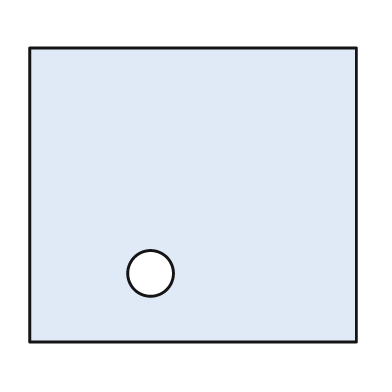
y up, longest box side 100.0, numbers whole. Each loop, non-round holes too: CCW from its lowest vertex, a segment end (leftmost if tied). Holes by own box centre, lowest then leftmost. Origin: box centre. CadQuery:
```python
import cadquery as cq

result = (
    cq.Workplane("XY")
    .moveTo(-50.0, -45.0)
    .lineTo(50.0, -45.0)
    .lineTo(50.0, 45.0)
    .lineTo(-50.0, 45.0)
    .close()
    .moveTo(-13.0, -24.0)
    .circle(7.0)
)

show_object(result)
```